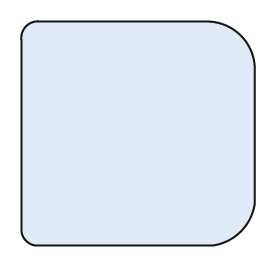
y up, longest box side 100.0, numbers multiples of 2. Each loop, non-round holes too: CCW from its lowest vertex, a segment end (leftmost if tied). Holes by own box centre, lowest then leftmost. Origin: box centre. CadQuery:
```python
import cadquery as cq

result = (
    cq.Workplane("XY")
    .moveTo(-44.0, -48.0)
    .lineTo(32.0, -48.0)
    .threePointArc((44.0, -42.0), (50.0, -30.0))
    .lineTo(50.0, 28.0)
    .threePointArc((44.0, 42.0), (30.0, 48.0))
    .lineTo(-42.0, 48.0)
    .threePointArc((-48.0, 46.0), (-50.0, 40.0))
    .lineTo(-50.0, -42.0)
    .threePointArc((-48.0, -46.0), (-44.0, -48.0))
    .close()
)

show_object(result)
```